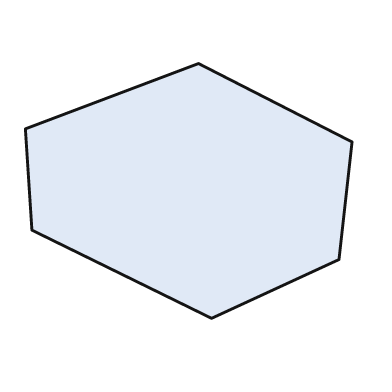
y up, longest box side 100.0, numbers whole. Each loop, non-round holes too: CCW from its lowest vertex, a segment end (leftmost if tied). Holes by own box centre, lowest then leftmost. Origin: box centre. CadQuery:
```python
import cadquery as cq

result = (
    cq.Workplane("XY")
    .moveTo(7.0, -39.0)
    .lineTo(46.0, -21.0)
    .lineTo(50.0, 15.0)
    .lineTo(3.0, 39.0)
    .lineTo(-50.0, 19.0)
    .lineTo(-48.0, -12.0)
    .close()
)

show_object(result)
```